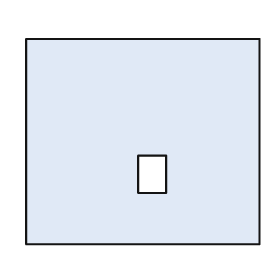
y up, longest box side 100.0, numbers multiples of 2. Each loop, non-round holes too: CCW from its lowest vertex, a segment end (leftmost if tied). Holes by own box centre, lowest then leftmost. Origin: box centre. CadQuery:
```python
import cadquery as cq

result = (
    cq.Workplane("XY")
    .moveTo(-50.0, -44.0)
    .lineTo(50.0, -44.0)
    .lineTo(50.0, 44.0)
    .lineTo(-50.0, 44.0)
    .close()
    .moveTo(-2.0, -22.0)
    .lineTo(10.0, -22.0)
    .lineTo(10.0, -6.0)
    .lineTo(-2.0, -6.0)
    .close()
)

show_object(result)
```